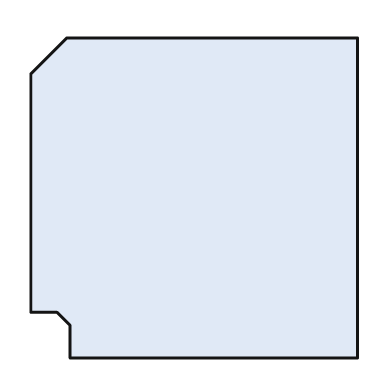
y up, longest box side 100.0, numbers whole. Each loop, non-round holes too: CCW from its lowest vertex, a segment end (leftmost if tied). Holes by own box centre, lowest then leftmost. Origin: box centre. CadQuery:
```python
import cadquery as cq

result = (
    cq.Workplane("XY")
    .moveTo(-38.0, -49.0)
    .lineTo(50.0, -49.0)
    .lineTo(50.0, 49.0)
    .lineTo(-39.0, 49.0)
    .lineTo(-50.0, 38.0)
    .lineTo(-50.0, -35.0)
    .lineTo(-42.0, -35.0)
    .lineTo(-38.0, -39.0)
    .close()
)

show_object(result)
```